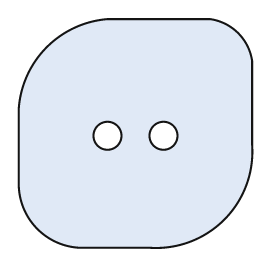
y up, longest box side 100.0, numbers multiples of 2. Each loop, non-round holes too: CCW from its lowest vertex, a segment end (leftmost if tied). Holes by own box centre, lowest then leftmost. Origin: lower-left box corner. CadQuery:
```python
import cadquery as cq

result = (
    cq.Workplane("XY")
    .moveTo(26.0, 0.0)
    .lineTo(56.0, 0.0)
    .threePointArc((88.0, 12.0), (100.0, 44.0))
    .lineTo(100.0, 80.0)
    .threePointArc((94.0, 92.0), (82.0, 98.0))
    .lineTo(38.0, 98.0)
    .threePointArc((12.0, 86.0), (0.0, 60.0))
    .lineTo(0.0, 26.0)
    .threePointArc((8.0, 8.0), (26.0, 0.0))
    .close()
    .moveTo(38.0, 48.0)
    .circle(6.0)
    .moveTo(62.0, 48.0)
    .circle(6.0)
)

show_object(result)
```